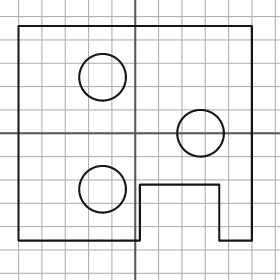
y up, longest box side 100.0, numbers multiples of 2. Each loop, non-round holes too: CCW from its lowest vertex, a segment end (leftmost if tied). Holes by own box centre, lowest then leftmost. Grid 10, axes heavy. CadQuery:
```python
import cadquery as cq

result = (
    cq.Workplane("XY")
    .moveTo(-50.0, -46.0)
    .lineTo(2.0, -46.0)
    .lineTo(2.0, -22.0)
    .lineTo(36.0, -22.0)
    .lineTo(36.0, -46.0)
    .lineTo(50.0, -46.0)
    .lineTo(50.0, 46.0)
    .lineTo(-50.0, 46.0)
    .close()
    .moveTo(-14.0, -24.0)
    .circle(10.0)
    .moveTo(28.0, 0.0)
    .circle(10.0)
    .moveTo(-14.0, 24.0)
    .circle(10.0)
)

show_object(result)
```